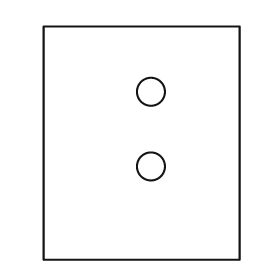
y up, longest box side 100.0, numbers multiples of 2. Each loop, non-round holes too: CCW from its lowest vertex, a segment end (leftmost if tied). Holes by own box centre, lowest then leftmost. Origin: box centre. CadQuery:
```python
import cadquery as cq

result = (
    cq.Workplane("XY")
    .moveTo(-42.0, -50.0)
    .lineTo(42.0, -50.0)
    .lineTo(42.0, 50.0)
    .lineTo(-42.0, 50.0)
    .close()
    .moveTo(4.0, -10.0)
    .circle(6.0)
    .moveTo(4.0, 22.0)
    .circle(6.0)
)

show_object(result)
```